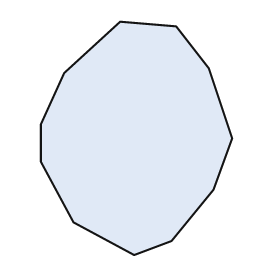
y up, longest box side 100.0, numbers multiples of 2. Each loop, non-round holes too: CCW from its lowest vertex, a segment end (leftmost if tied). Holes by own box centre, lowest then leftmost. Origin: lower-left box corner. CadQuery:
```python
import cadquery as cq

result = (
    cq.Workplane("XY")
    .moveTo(40.0, 0.0)
    .lineTo(56.0, 6.0)
    .lineTo(74.0, 28.0)
    .lineTo(82.0, 50.0)
    .lineTo(72.0, 80.0)
    .lineTo(58.0, 98.0)
    .lineTo(34.0, 100.0)
    .lineTo(10.0, 78.0)
    .lineTo(0.0, 56.0)
    .lineTo(0.0, 40.0)
    .lineTo(14.0, 14.0)
    .close()
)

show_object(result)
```